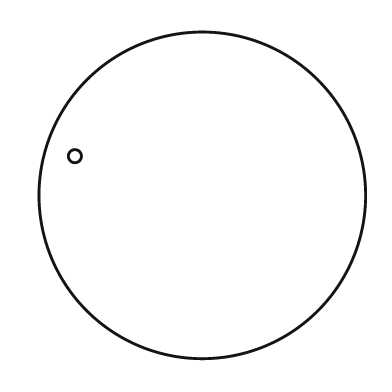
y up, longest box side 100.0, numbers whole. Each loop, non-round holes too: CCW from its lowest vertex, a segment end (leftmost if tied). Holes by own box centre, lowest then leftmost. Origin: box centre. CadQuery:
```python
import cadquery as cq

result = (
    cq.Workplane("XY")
    .moveTo(0.0, 0.0)
    .circle(50.0)
    .moveTo(-39.0, 12.0)
    .circle(2.0)
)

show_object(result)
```